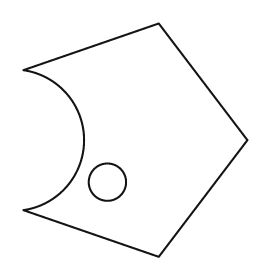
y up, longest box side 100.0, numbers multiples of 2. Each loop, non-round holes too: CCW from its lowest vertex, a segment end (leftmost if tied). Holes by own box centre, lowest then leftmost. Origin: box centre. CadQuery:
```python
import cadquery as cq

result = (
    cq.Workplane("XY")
    .moveTo(10.0, -50.0)
    .lineTo(48.0, 0.0)
    .lineTo(10.0, 50.0)
    .lineTo(-48.0, 30.0)
    .threePointArc((-22.0, 0.0), (-48.0, -30.0))
    .close()
    .moveTo(-12.0, -18.0)
    .circle(8.0)
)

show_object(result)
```